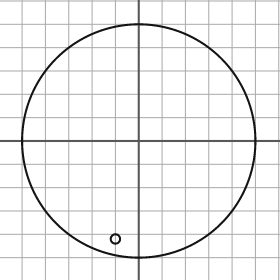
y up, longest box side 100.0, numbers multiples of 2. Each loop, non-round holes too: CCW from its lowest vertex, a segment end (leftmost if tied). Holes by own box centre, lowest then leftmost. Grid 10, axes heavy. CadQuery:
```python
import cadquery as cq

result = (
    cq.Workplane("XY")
    .moveTo(0.0, 0.0)
    .circle(50.0)
    .moveTo(-10.0, -42.0)
    .circle(2.0)
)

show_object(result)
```